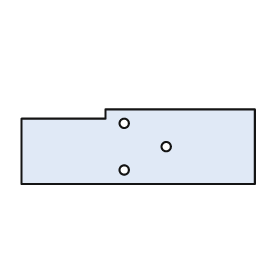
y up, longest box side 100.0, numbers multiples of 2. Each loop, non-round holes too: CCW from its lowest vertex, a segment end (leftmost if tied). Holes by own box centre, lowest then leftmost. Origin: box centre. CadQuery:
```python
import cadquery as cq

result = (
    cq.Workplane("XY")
    .moveTo(-50.0, -16.0)
    .lineTo(50.0, -16.0)
    .lineTo(50.0, 16.0)
    .lineTo(-14.0, 16.0)
    .lineTo(-14.0, 12.0)
    .lineTo(-50.0, 12.0)
    .close()
    .moveTo(-6.0, -10.0)
    .circle(2.0)
    .moveTo(12.0, 0.0)
    .circle(2.0)
    .moveTo(-6.0, 10.0)
    .circle(2.0)
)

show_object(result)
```